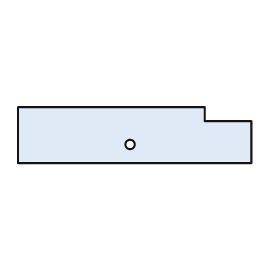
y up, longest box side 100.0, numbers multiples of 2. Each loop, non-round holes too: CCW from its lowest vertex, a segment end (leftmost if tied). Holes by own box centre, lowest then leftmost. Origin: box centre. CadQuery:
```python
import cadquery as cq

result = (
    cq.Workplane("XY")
    .moveTo(-50.0, -12.0)
    .lineTo(50.0, -12.0)
    .lineTo(50.0, 6.0)
    .lineTo(30.0, 6.0)
    .lineTo(30.0, 12.0)
    .lineTo(-50.0, 12.0)
    .close()
    .moveTo(-2.0, -4.0)
    .circle(2.0)
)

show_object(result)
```